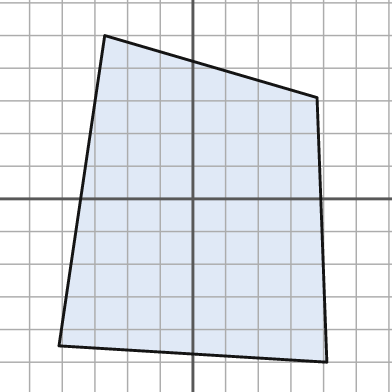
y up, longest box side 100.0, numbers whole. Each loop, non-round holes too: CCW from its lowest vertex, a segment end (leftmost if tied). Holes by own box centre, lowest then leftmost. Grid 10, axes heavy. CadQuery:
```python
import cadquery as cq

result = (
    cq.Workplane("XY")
    .moveTo(41.0, -50.0)
    .lineTo(38.0, 31.0)
    .lineTo(-27.0, 50.0)
    .lineTo(-41.0, -45.0)
    .close()
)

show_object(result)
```